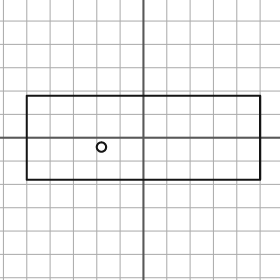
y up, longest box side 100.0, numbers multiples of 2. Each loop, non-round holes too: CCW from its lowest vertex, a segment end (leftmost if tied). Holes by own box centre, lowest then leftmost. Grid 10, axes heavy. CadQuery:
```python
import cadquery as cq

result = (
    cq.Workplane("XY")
    .moveTo(-50.0, -18.0)
    .lineTo(50.0, -18.0)
    .lineTo(50.0, 18.0)
    .lineTo(-50.0, 18.0)
    .close()
    .moveTo(-18.0, -4.0)
    .circle(2.0)
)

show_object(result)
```